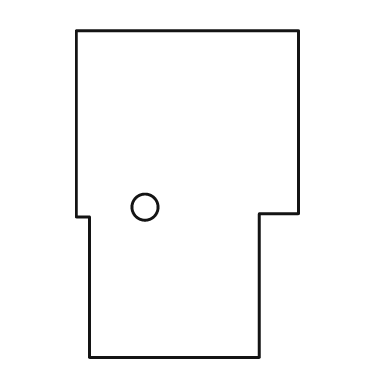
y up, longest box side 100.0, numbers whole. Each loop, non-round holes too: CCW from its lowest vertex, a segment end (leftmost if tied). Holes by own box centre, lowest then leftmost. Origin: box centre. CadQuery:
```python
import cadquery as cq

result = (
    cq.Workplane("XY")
    .moveTo(-30.0, -50.0)
    .lineTo(22.0, -50.0)
    .lineTo(22.0, -6.0)
    .lineTo(34.0, -6.0)
    .lineTo(34.0, 50.0)
    .lineTo(-34.0, 50.0)
    .lineTo(-34.0, -7.0)
    .lineTo(-30.0, -7.0)
    .close()
    .moveTo(-13.0, -4.0)
    .circle(4.0)
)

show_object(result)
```